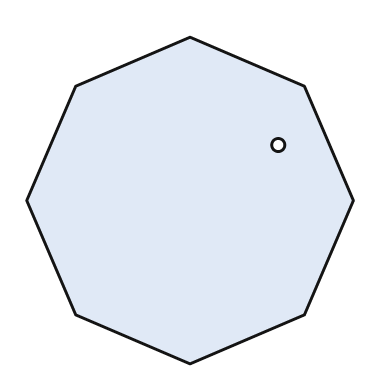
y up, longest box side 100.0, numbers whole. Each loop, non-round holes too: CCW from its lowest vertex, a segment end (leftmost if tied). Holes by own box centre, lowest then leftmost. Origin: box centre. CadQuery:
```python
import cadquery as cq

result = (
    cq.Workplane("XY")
    .moveTo(0.0, -50.0)
    .lineTo(35.0, -35.0)
    .lineTo(50.0, 0.0)
    .lineTo(35.0, 35.0)
    .lineTo(0.0, 50.0)
    .lineTo(-35.0, 35.0)
    .lineTo(-50.0, 0.0)
    .lineTo(-35.0, -35.0)
    .close()
    .moveTo(27.0, 17.0)
    .circle(2.0)
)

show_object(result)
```